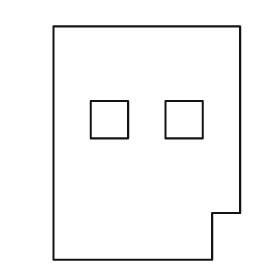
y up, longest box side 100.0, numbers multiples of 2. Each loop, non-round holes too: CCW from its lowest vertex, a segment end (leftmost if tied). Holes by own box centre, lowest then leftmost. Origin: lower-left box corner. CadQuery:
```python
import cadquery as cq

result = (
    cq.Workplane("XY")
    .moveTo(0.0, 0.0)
    .lineTo(68.0, 0.0)
    .lineTo(68.0, 20.0)
    .lineTo(80.0, 20.0)
    .lineTo(80.0, 100.0)
    .lineTo(0.0, 100.0)
    .close()
    .moveTo(16.0, 52.0)
    .lineTo(32.0, 52.0)
    .lineTo(32.0, 68.0)
    .lineTo(16.0, 68.0)
    .close()
    .moveTo(48.0, 52.0)
    .lineTo(64.0, 52.0)
    .lineTo(64.0, 68.0)
    .lineTo(48.0, 68.0)
    .close()
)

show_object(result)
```